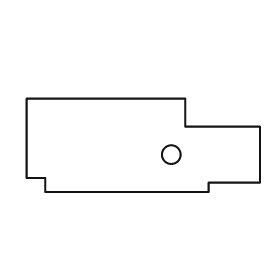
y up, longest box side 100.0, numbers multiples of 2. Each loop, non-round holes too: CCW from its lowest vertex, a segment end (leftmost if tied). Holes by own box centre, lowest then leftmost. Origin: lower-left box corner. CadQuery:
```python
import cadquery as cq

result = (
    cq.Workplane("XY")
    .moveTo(8.0, 0.0)
    .lineTo(78.0, 0.0)
    .lineTo(78.0, 4.0)
    .lineTo(100.0, 4.0)
    .lineTo(100.0, 28.0)
    .lineTo(68.0, 28.0)
    .lineTo(68.0, 40.0)
    .lineTo(0.0, 40.0)
    .lineTo(0.0, 6.0)
    .lineTo(8.0, 6.0)
    .close()
    .moveTo(62.0, 16.0)
    .circle(4.0)
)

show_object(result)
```